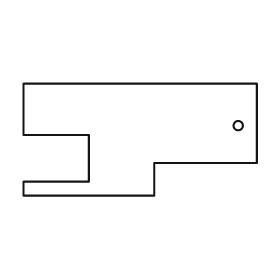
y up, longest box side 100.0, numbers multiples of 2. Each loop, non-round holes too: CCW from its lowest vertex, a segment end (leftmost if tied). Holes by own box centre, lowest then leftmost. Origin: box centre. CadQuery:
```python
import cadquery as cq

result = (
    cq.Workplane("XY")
    .moveTo(-50.0, -24.0)
    .lineTo(6.0, -24.0)
    .lineTo(6.0, -10.0)
    .lineTo(50.0, -10.0)
    .lineTo(50.0, 24.0)
    .lineTo(-50.0, 24.0)
    .lineTo(-50.0, 2.0)
    .lineTo(-22.0, 2.0)
    .lineTo(-22.0, -18.0)
    .lineTo(-50.0, -18.0)
    .close()
    .moveTo(42.0, 6.0)
    .circle(2.0)
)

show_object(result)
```